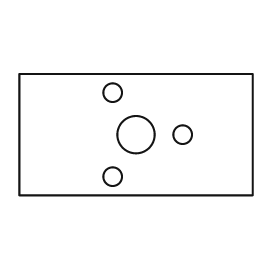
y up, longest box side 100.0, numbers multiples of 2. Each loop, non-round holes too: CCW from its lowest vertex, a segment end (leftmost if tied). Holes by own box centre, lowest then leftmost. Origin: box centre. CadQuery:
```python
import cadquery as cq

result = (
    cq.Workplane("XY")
    .moveTo(-50.0, -26.0)
    .lineTo(50.0, -26.0)
    .lineTo(50.0, 26.0)
    .lineTo(-50.0, 26.0)
    .close()
    .moveTo(-10.0, -18.0)
    .circle(4.0)
    .moveTo(0.0, 0.0)
    .circle(8.0)
    .moveTo(20.0, 0.0)
    .circle(4.0)
    .moveTo(-10.0, 18.0)
    .circle(4.0)
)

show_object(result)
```